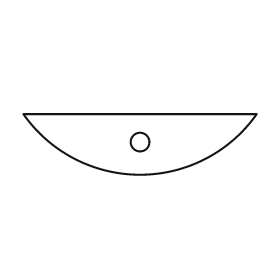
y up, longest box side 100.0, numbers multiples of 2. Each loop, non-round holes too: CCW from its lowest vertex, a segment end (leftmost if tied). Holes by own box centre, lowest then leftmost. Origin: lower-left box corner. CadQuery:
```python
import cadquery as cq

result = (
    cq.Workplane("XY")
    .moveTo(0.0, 26.0)
    .threePointArc((50.0, 0.0), (100.0, 26.0))
    .close()
    .moveTo(50.0, 14.0)
    .circle(4.0)
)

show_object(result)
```